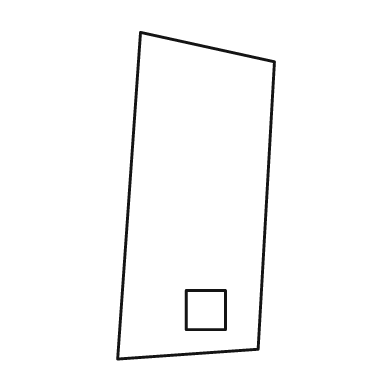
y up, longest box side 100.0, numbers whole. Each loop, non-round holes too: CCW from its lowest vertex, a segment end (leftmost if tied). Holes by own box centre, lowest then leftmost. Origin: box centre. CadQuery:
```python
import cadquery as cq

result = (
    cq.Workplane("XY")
    .moveTo(-24.0, -50.0)
    .lineTo(19.0, -47.0)
    .lineTo(24.0, 41.0)
    .lineTo(-17.0, 50.0)
    .close()
    .moveTo(-3.0, -41.0)
    .lineTo(9.0, -41.0)
    .lineTo(9.0, -29.0)
    .lineTo(-3.0, -29.0)
    .close()
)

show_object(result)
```